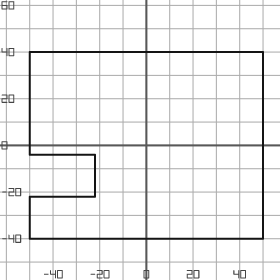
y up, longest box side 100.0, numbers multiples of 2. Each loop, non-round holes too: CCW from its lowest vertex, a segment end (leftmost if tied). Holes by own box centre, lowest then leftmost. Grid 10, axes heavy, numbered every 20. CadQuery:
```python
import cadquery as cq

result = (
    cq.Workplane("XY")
    .moveTo(-50.0, -40.0)
    .lineTo(50.0, -40.0)
    .lineTo(50.0, 40.0)
    .lineTo(-50.0, 40.0)
    .lineTo(-50.0, -4.0)
    .lineTo(-22.0, -4.0)
    .lineTo(-22.0, -22.0)
    .lineTo(-50.0, -22.0)
    .close()
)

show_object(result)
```